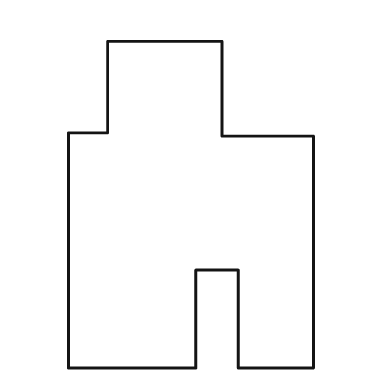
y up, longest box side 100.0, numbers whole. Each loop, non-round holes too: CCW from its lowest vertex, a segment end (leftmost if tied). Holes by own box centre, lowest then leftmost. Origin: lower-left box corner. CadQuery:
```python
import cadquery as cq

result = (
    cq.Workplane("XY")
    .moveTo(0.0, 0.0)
    .lineTo(39.0, 0.0)
    .lineTo(39.0, 30.0)
    .lineTo(52.0, 30.0)
    .lineTo(52.0, 0.0)
    .lineTo(75.0, 0.0)
    .lineTo(75.0, 71.0)
    .lineTo(47.0, 71.0)
    .lineTo(47.0, 100.0)
    .lineTo(12.0, 100.0)
    .lineTo(12.0, 72.0)
    .lineTo(0.0, 72.0)
    .close()
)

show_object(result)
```